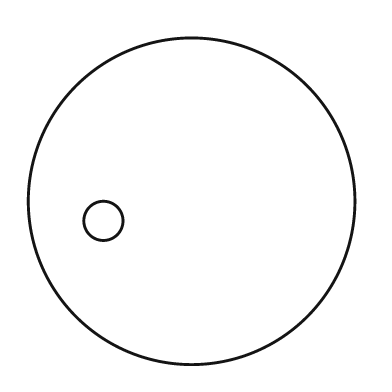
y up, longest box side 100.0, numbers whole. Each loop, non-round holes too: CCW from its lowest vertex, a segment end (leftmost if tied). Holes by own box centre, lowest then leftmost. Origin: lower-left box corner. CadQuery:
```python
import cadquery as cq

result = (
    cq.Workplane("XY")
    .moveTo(50.0, 50.0)
    .circle(50.0)
    .moveTo(23.0, 44.0)
    .circle(6.0)
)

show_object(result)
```